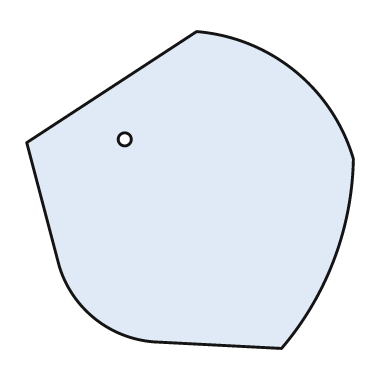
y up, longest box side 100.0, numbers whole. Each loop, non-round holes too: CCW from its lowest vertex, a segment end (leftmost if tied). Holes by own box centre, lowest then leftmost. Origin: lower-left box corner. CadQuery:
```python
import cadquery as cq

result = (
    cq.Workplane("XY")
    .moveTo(78.0, 0.0)
    .threePointArc((94.0, 27.0), (100.0, 58.0))
    .threePointArc((82.0, 85.0), (52.0, 97.0))
    .lineTo(0.0, 63.0)
    .lineTo(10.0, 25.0)
    .threePointArc((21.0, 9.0), (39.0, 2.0))
    .close()
    .moveTo(30.0, 64.0)
    .circle(2.0)
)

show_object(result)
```